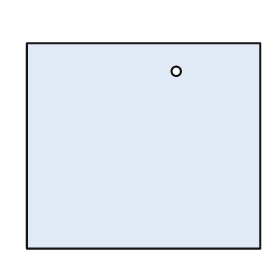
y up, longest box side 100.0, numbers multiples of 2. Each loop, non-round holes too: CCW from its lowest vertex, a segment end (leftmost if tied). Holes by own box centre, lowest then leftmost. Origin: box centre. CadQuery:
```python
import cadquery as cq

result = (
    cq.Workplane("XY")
    .moveTo(-50.0, -44.0)
    .lineTo(50.0, -44.0)
    .lineTo(50.0, 44.0)
    .lineTo(-50.0, 44.0)
    .close()
    .moveTo(14.0, 32.0)
    .circle(2.0)
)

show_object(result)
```